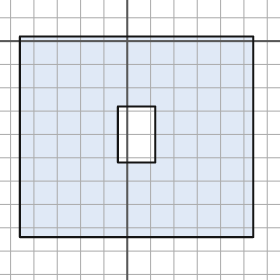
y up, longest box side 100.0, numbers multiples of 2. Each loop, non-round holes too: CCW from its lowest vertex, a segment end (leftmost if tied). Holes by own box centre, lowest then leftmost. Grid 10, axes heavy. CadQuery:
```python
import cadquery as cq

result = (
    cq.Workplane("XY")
    .moveTo(-46.0, -84.0)
    .lineTo(54.0, -84.0)
    .lineTo(54.0, 2.0)
    .lineTo(-46.0, 2.0)
    .close()
    .moveTo(-4.0, -52.0)
    .lineTo(12.0, -52.0)
    .lineTo(12.0, -28.0)
    .lineTo(-4.0, -28.0)
    .close()
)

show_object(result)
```